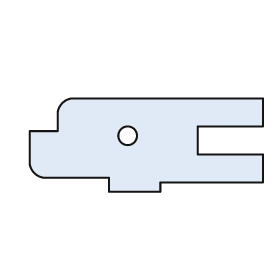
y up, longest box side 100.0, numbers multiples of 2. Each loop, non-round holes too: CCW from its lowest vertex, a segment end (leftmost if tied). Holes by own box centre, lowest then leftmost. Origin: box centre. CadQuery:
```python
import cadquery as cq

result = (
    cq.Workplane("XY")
    .moveTo(-16.0, -20.0)
    .lineTo(6.0, -20.0)
    .lineTo(6.0, -16.0)
    .lineTo(50.0, -16.0)
    .lineTo(50.0, -4.0)
    .lineTo(22.0, -4.0)
    .lineTo(22.0, 8.0)
    .lineTo(50.0, 8.0)
    .lineTo(50.0, 20.0)
    .lineTo(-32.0, 20.0)
    .threePointArc((-36.0, 18.0), (-38.0, 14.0))
    .lineTo(-38.0, 6.0)
    .lineTo(-50.0, 6.0)
    .lineTo(-50.0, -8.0)
    .threePointArc((-48.0, -12.0), (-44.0, -14.0))
    .lineTo(-16.0, -14.0)
    .close()
    .moveTo(-8.0, 4.0)
    .circle(4.0)
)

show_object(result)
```